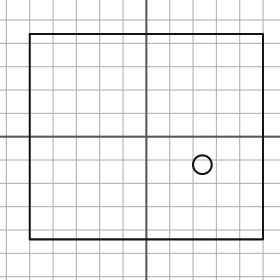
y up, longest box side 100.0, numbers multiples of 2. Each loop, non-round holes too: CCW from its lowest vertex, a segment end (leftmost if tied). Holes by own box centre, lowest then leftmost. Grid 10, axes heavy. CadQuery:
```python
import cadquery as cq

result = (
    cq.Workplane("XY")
    .moveTo(-50.0, -44.0)
    .lineTo(50.0, -44.0)
    .lineTo(50.0, 44.0)
    .lineTo(-50.0, 44.0)
    .close()
    .moveTo(24.0, -12.0)
    .circle(4.0)
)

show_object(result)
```